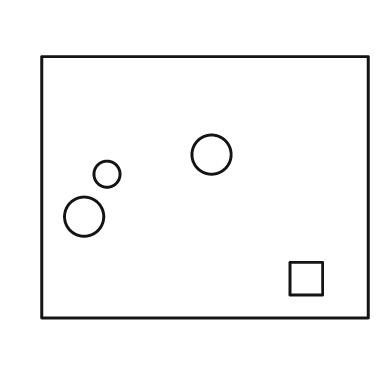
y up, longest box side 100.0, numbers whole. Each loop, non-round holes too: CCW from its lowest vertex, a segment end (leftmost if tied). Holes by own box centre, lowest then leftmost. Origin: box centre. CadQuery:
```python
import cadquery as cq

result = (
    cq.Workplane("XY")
    .moveTo(-50.0, -40.0)
    .lineTo(50.0, -40.0)
    .lineTo(50.0, 40.0)
    .lineTo(-50.0, 40.0)
    .close()
    .moveTo(26.0, -33.0)
    .lineTo(36.0, -33.0)
    .lineTo(36.0, -23.0)
    .lineTo(26.0, -23.0)
    .close()
    .moveTo(-37.0, -9.0)
    .circle(6.0)
    .moveTo(-30.0, 4.0)
    .circle(4.0)
    .moveTo(2.0, 10.0)
    .circle(6.0)
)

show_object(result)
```